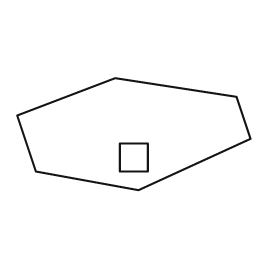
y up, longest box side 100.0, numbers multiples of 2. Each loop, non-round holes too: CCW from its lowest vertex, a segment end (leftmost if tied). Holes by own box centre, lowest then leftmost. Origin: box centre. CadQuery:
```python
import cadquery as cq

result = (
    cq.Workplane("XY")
    .moveTo(2.0, -24.0)
    .lineTo(50.0, -2.0)
    .lineTo(44.0, 16.0)
    .lineTo(-8.0, 24.0)
    .lineTo(-50.0, 8.0)
    .lineTo(-42.0, -16.0)
    .close()
    .moveTo(-6.0, -16.0)
    .lineTo(6.0, -16.0)
    .lineTo(6.0, -4.0)
    .lineTo(-6.0, -4.0)
    .close()
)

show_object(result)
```